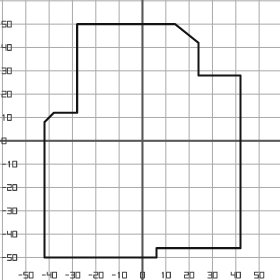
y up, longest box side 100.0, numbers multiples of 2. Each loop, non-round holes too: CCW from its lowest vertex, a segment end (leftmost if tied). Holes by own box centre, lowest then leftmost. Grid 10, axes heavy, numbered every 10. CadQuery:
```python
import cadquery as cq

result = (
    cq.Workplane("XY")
    .moveTo(-42.0, -50.0)
    .lineTo(6.0, -50.0)
    .lineTo(6.0, -46.0)
    .lineTo(42.0, -46.0)
    .lineTo(42.0, 28.0)
    .lineTo(24.0, 28.0)
    .lineTo(24.0, 42.0)
    .lineTo(14.0, 50.0)
    .lineTo(-28.0, 50.0)
    .lineTo(-28.0, 12.0)
    .lineTo(-38.0, 12.0)
    .lineTo(-42.0, 8.0)
    .close()
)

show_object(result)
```